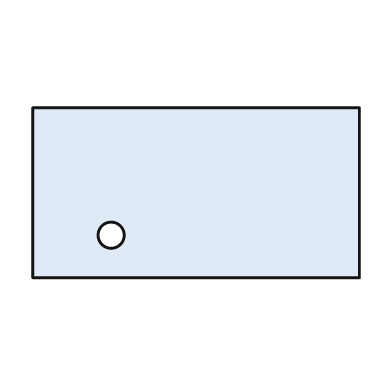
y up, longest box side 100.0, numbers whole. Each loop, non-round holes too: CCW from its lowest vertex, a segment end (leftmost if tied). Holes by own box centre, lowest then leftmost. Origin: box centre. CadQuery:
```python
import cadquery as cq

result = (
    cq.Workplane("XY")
    .moveTo(-50.0, -26.0)
    .lineTo(50.0, -26.0)
    .lineTo(50.0, 26.0)
    .lineTo(-50.0, 26.0)
    .close()
    .moveTo(-26.0, -13.0)
    .circle(4.0)
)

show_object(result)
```